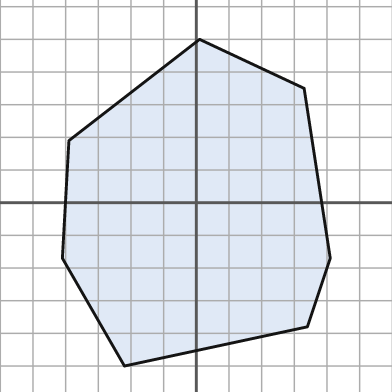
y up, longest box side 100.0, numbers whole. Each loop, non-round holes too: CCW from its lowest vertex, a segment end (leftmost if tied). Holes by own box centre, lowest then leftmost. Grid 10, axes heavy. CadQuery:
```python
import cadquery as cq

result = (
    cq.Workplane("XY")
    .moveTo(-22.0, -50.0)
    .lineTo(34.0, -38.0)
    .lineTo(41.0, -17.0)
    .lineTo(33.0, 35.0)
    .lineTo(1.0, 50.0)
    .lineTo(-39.0, 19.0)
    .lineTo(-41.0, -17.0)
    .close()
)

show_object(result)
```